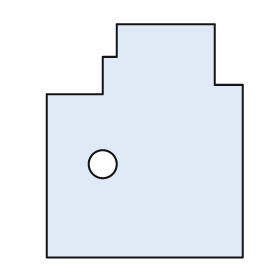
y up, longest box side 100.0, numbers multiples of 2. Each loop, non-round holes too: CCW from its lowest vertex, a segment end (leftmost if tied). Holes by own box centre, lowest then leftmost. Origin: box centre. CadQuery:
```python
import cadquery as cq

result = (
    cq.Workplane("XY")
    .moveTo(-42.0, -50.0)
    .lineTo(42.0, -50.0)
    .lineTo(42.0, 24.0)
    .lineTo(30.0, 24.0)
    .lineTo(30.0, 50.0)
    .lineTo(-12.0, 50.0)
    .lineTo(-12.0, 36.0)
    .lineTo(-18.0, 36.0)
    .lineTo(-18.0, 20.0)
    .lineTo(-42.0, 20.0)
    .close()
    .moveTo(-18.0, -10.0)
    .circle(6.0)
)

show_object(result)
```